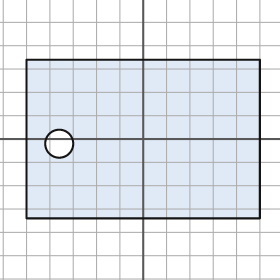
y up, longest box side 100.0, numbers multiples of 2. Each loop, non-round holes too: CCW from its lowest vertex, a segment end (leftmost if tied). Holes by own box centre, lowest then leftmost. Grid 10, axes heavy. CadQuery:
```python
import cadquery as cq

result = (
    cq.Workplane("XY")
    .moveTo(-50.0, -34.0)
    .lineTo(50.0, -34.0)
    .lineTo(50.0, 34.0)
    .lineTo(-50.0, 34.0)
    .close()
    .moveTo(-36.0, -2.0)
    .circle(6.0)
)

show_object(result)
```